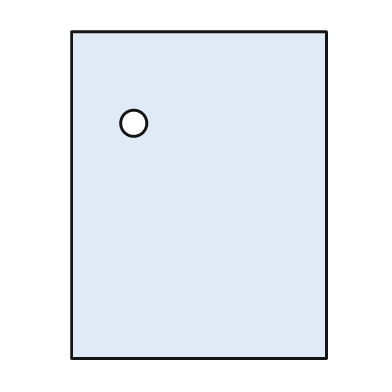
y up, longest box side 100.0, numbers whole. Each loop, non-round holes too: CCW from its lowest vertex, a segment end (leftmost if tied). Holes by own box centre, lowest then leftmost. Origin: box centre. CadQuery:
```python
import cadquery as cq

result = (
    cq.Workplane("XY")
    .moveTo(-39.0, -50.0)
    .lineTo(39.0, -50.0)
    .lineTo(39.0, 50.0)
    .lineTo(-39.0, 50.0)
    .close()
    .moveTo(-20.0, 22.0)
    .circle(4.0)
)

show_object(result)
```